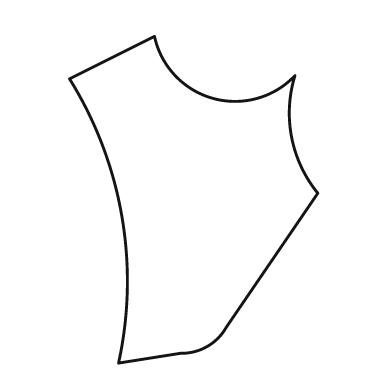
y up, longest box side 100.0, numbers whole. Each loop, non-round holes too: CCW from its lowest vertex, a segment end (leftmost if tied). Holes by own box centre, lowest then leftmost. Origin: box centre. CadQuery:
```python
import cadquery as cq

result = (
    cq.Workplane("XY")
    .moveTo(-23.0, -50.0)
    .lineTo(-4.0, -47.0)
    .threePointArc((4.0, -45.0), (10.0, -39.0))
    .lineTo(38.0, 2.0)
    .threePointArc((30.0, 19.0), (31.0, 38.0))
    .threePointArc((6.0, 31.0), (-12.0, 50.0))
    .lineTo(-38.0, 37.0)
    .threePointArc((-22.0, -5.0), (-23.0, -50.0))
    .close()
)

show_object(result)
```